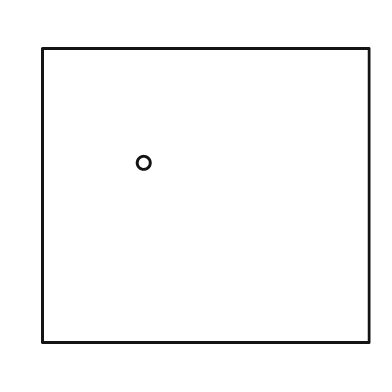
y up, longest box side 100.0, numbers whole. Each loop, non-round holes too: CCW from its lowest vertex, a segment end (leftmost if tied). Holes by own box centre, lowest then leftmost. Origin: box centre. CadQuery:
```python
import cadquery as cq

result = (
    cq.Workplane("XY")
    .moveTo(-50.0, -45.0)
    .lineTo(50.0, -45.0)
    .lineTo(50.0, 45.0)
    .lineTo(-50.0, 45.0)
    .close()
    .moveTo(-19.0, 10.0)
    .circle(2.0)
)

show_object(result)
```